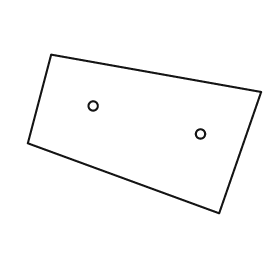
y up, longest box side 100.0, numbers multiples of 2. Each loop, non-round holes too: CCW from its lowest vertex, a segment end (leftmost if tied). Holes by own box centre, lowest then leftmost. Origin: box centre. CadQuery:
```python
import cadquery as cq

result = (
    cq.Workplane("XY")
    .moveTo(32.0, -34.0)
    .lineTo(50.0, 18.0)
    .lineTo(-40.0, 34.0)
    .lineTo(-50.0, -4.0)
    .close()
    .moveTo(24.0, 0.0)
    .circle(2.0)
    .moveTo(-22.0, 12.0)
    .circle(2.0)
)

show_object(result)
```